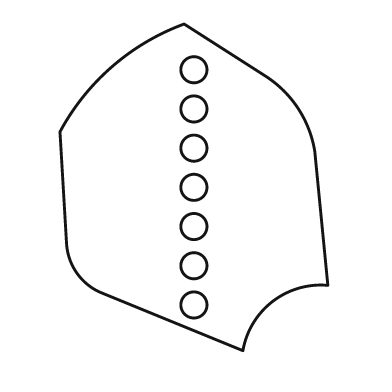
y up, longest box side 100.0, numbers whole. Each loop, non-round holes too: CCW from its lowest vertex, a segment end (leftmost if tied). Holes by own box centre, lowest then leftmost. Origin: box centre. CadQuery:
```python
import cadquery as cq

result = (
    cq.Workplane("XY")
    .moveTo(15.0, -50.0)
    .threePointArc((24.0, -35.0), (41.0, -30.0))
    .lineTo(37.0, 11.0)
    .threePointArc((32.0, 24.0), (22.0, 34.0))
    .lineTo(-3.0, 50.0)
    .threePointArc((-25.0, 37.0), (-41.0, 17.0))
    .lineTo(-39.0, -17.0)
    .threePointArc((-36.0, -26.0), (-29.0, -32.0))
    .close()
    .moveTo(0.0, -36.0)
    .circle(4.0)
    .moveTo(0.0, -24.0)
    .circle(4.0)
    .moveTo(0.0, -12.0)
    .circle(4.0)
    .moveTo(0.0, 0.0)
    .circle(4.0)
    .moveTo(0.0, 12.0)
    .circle(4.0)
    .moveTo(0.0, 24.0)
    .circle(4.0)
    .moveTo(0.0, 36.0)
    .circle(4.0)
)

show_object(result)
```